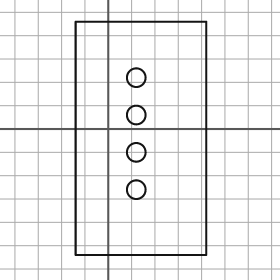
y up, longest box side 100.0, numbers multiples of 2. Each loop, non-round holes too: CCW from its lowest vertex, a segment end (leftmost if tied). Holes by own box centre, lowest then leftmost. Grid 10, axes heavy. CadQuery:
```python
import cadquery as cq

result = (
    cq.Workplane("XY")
    .moveTo(-14.0, -54.0)
    .lineTo(42.0, -54.0)
    .lineTo(42.0, 46.0)
    .lineTo(-14.0, 46.0)
    .close()
    .moveTo(12.0, -26.0)
    .circle(4.0)
    .moveTo(12.0, -10.0)
    .circle(4.0)
    .moveTo(12.0, 6.0)
    .circle(4.0)
    .moveTo(12.0, 22.0)
    .circle(4.0)
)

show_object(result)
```